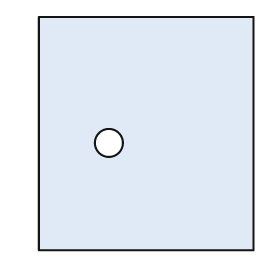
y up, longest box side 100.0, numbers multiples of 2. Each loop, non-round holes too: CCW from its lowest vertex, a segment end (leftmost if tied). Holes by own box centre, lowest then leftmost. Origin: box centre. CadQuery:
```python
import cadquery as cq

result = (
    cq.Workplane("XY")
    .moveTo(-46.0, -50.0)
    .lineTo(46.0, -50.0)
    .lineTo(46.0, 50.0)
    .lineTo(-46.0, 50.0)
    .close()
    .moveTo(-16.0, -4.0)
    .circle(6.0)
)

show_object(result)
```